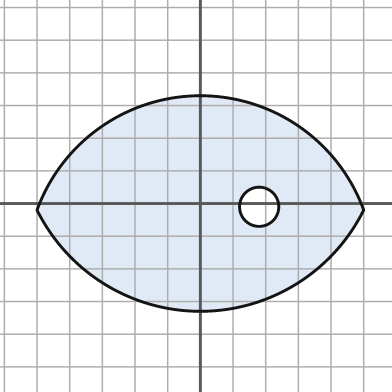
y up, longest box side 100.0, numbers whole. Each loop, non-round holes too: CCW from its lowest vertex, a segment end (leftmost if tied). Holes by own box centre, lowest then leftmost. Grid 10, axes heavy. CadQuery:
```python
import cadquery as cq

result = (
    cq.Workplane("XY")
    .moveTo(-50.0, -2.0)
    .threePointArc((0.0, -33.0), (50.0, -2.0))
    .threePointArc((0.0, 33.0), (-50.0, -2.0))
    .close()
    .moveTo(18.0, -1.0)
    .circle(6.0)
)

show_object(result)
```